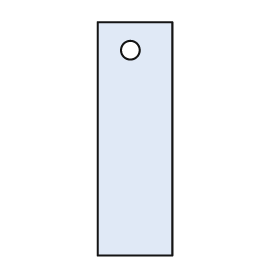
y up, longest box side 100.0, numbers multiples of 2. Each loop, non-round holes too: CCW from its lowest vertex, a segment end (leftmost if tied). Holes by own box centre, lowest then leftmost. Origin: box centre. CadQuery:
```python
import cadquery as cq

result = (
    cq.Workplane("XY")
    .moveTo(-16.0, -50.0)
    .lineTo(16.0, -50.0)
    .lineTo(16.0, 50.0)
    .lineTo(-16.0, 50.0)
    .close()
    .moveTo(-2.0, 38.0)
    .circle(4.0)
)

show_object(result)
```